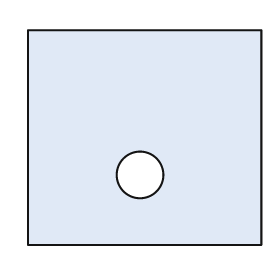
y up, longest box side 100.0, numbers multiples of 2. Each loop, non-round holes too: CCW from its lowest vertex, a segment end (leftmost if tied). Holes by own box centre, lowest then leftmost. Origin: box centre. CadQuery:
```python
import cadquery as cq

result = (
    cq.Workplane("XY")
    .moveTo(-50.0, -46.0)
    .lineTo(50.0, -46.0)
    .lineTo(50.0, 46.0)
    .lineTo(-50.0, 46.0)
    .close()
    .moveTo(-2.0, -16.0)
    .circle(10.0)
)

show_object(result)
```